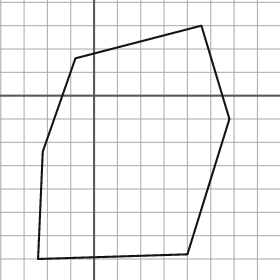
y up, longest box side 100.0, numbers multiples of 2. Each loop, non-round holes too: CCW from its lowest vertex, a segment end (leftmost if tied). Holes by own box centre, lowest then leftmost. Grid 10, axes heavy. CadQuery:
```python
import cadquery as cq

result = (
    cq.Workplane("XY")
    .moveTo(-24.0, -70.0)
    .lineTo(40.0, -68.0)
    .lineTo(58.0, -10.0)
    .lineTo(46.0, 30.0)
    .lineTo(-8.0, 16.0)
    .lineTo(-22.0, -24.0)
    .close()
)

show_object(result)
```